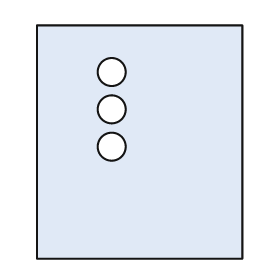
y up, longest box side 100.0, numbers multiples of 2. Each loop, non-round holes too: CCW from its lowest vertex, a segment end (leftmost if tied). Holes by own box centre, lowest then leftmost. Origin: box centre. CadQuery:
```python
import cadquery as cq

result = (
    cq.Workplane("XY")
    .moveTo(-44.0, -50.0)
    .lineTo(44.0, -50.0)
    .lineTo(44.0, 50.0)
    .lineTo(-44.0, 50.0)
    .close()
    .moveTo(-12.0, -2.0)
    .circle(6.0)
    .moveTo(-12.0, 14.0)
    .circle(6.0)
    .moveTo(-12.0, 30.0)
    .circle(6.0)
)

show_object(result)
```